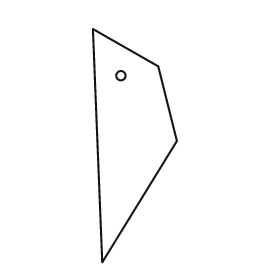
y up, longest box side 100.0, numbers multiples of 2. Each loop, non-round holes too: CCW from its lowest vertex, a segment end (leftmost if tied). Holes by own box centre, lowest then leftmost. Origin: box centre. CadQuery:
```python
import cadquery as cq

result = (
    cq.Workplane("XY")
    .moveTo(-14.0, -50.0)
    .lineTo(18.0, 2.0)
    .lineTo(10.0, 34.0)
    .lineTo(-18.0, 50.0)
    .close()
    .moveTo(-6.0, 30.0)
    .circle(2.0)
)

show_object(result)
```